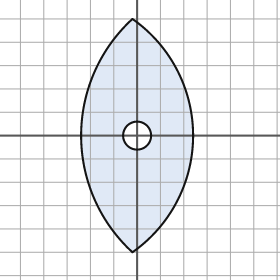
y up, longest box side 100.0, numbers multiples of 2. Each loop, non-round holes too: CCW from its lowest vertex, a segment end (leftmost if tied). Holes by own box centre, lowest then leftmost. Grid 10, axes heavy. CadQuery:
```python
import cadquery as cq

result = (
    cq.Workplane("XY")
    .moveTo(-2.0, -50.0)
    .threePointArc((24.0, 0.0), (-2.0, 50.0))
    .threePointArc((-24.0, 0.0), (-2.0, -50.0))
    .close()
    .moveTo(0.0, 0.0)
    .circle(6.0)
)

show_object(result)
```